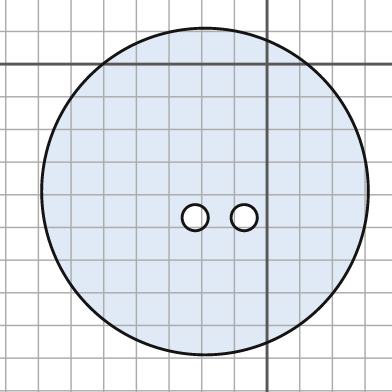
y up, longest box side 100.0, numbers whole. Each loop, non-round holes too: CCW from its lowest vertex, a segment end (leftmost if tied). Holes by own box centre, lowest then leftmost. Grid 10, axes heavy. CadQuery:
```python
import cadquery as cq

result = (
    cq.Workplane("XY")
    .moveTo(-19.0, -39.0)
    .circle(50.0)
    .moveTo(-22.0, -47.0)
    .circle(4.0)
    .moveTo(-7.0, -47.0)
    .circle(4.0)
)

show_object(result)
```